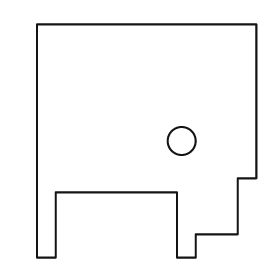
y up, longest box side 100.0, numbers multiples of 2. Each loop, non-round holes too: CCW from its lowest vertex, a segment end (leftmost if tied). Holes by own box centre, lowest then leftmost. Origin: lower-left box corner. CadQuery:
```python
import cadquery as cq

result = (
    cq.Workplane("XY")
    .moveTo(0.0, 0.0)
    .lineTo(8.0, 0.0)
    .lineTo(8.0, 28.0)
    .lineTo(60.0, 28.0)
    .lineTo(60.0, 0.0)
    .lineTo(68.0, 0.0)
    .lineTo(68.0, 10.0)
    .lineTo(86.0, 10.0)
    .lineTo(86.0, 34.0)
    .lineTo(94.0, 34.0)
    .lineTo(94.0, 100.0)
    .lineTo(0.0, 100.0)
    .close()
    .moveTo(62.0, 50.0)
    .circle(6.0)
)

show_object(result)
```